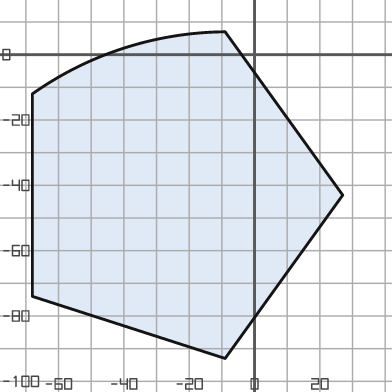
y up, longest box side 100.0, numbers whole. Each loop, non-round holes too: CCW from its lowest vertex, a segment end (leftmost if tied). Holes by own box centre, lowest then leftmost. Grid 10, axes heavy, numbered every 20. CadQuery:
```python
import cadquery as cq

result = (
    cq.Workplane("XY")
    .moveTo(-9.0, -93.0)
    .lineTo(27.0, -43.0)
    .lineTo(-9.0, 7.0)
    .threePointArc((-40.0, 2.0), (-68.0, -12.0))
    .lineTo(-68.0, -74.0)
    .close()
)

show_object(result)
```